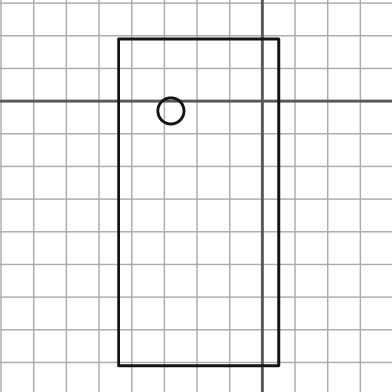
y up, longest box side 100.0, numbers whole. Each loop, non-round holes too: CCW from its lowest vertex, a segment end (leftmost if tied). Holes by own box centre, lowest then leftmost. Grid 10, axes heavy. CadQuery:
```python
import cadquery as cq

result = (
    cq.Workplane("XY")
    .moveTo(-44.0, -81.0)
    .lineTo(5.0, -81.0)
    .lineTo(5.0, 19.0)
    .lineTo(-44.0, 19.0)
    .close()
    .moveTo(-28.0, -3.0)
    .circle(4.0)
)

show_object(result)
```